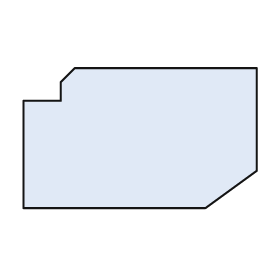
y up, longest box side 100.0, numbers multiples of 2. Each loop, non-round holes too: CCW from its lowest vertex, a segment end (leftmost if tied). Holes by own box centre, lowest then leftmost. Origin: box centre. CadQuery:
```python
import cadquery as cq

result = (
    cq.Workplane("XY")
    .moveTo(-50.0, -30.0)
    .lineTo(28.0, -30.0)
    .lineTo(50.0, -14.0)
    .lineTo(50.0, 30.0)
    .lineTo(-28.0, 30.0)
    .lineTo(-34.0, 24.0)
    .lineTo(-34.0, 16.0)
    .lineTo(-50.0, 16.0)
    .close()
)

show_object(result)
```